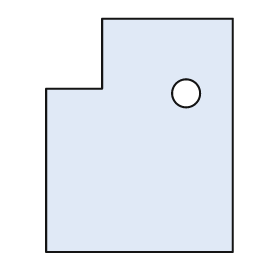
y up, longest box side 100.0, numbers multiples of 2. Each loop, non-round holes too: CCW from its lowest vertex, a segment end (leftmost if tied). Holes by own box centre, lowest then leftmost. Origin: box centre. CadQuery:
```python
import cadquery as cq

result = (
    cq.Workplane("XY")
    .moveTo(-40.0, -50.0)
    .lineTo(40.0, -50.0)
    .lineTo(40.0, 50.0)
    .lineTo(-16.0, 50.0)
    .lineTo(-16.0, 20.0)
    .lineTo(-40.0, 20.0)
    .close()
    .moveTo(20.0, 18.0)
    .circle(6.0)
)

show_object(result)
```